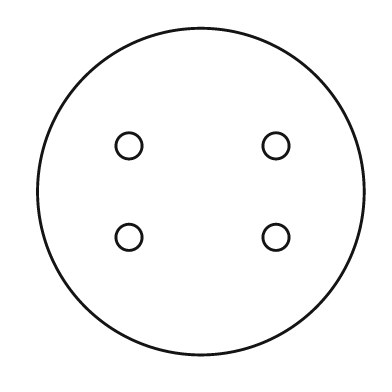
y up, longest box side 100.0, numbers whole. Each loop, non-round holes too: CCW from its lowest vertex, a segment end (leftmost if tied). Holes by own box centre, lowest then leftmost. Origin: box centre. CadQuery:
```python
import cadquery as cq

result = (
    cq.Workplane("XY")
    .moveTo(0.0, 0.0)
    .circle(50.0)
    .moveTo(-22.0, -14.0)
    .circle(4.0)
    .moveTo(23.0, -14.0)
    .circle(4.0)
    .moveTo(-22.0, 14.0)
    .circle(4.0)
    .moveTo(23.0, 14.0)
    .circle(4.0)
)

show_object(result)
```